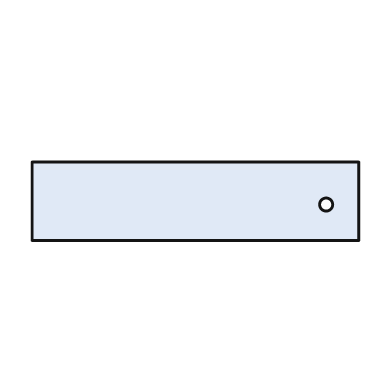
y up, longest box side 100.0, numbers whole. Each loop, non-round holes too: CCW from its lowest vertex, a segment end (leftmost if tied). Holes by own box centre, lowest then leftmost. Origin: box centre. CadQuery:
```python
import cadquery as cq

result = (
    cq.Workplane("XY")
    .moveTo(-50.0, -12.0)
    .lineTo(50.0, -12.0)
    .lineTo(50.0, 12.0)
    .lineTo(-50.0, 12.0)
    .close()
    .moveTo(40.0, -1.0)
    .circle(2.0)
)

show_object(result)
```